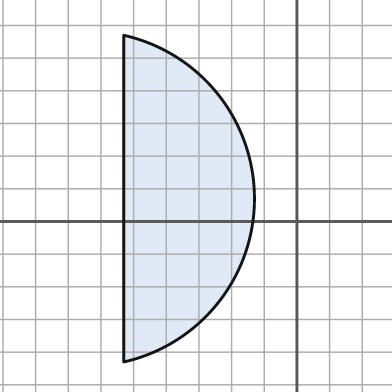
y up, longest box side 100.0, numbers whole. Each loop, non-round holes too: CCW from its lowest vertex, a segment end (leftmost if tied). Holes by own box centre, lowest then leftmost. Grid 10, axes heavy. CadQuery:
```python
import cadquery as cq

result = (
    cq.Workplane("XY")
    .moveTo(-53.0, -43.0)
    .threePointArc((-13.0, 7.0), (-53.0, 57.0))
    .close()
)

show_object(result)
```